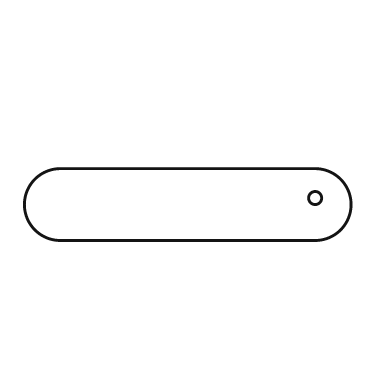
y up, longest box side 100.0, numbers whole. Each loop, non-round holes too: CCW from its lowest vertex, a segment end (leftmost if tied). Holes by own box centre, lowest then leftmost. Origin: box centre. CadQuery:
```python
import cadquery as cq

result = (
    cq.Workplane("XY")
    .moveTo(-39.0, -11.0)
    .lineTo(39.0, -11.0)
    .threePointArc((50.0, 0.0), (39.0, 11.0))
    .lineTo(-39.0, 11.0)
    .threePointArc((-50.0, 0.0), (-39.0, -11.0))
    .close()
    .moveTo(39.0, 2.0)
    .circle(2.0)
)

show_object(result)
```